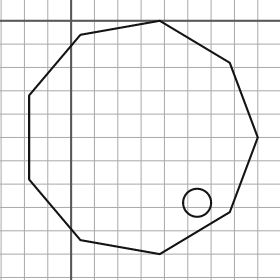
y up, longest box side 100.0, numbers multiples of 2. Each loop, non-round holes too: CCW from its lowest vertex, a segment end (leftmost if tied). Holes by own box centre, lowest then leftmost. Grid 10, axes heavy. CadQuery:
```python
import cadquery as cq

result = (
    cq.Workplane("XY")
    .moveTo(38.0, -100.0)
    .lineTo(68.0, -82.0)
    .lineTo(80.0, -50.0)
    .lineTo(68.0, -18.0)
    .lineTo(38.0, 0.0)
    .lineTo(4.0, -6.0)
    .lineTo(-18.0, -32.0)
    .lineTo(-18.0, -68.0)
    .lineTo(4.0, -94.0)
    .close()
    .moveTo(54.0, -78.0)
    .circle(6.0)
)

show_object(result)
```